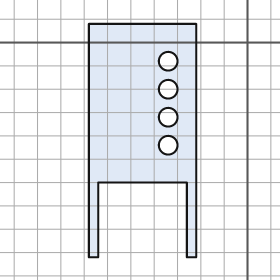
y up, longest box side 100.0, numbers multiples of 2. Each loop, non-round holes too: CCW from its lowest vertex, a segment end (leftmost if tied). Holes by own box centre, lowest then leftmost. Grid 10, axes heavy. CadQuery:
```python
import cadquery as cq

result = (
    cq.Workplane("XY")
    .moveTo(-68.0, -92.0)
    .lineTo(-64.0, -92.0)
    .lineTo(-64.0, -60.0)
    .lineTo(-26.0, -60.0)
    .lineTo(-26.0, -92.0)
    .lineTo(-22.0, -92.0)
    .lineTo(-22.0, 8.0)
    .lineTo(-68.0, 8.0)
    .close()
    .moveTo(-34.0, -44.0)
    .circle(4.0)
    .moveTo(-34.0, -32.0)
    .circle(4.0)
    .moveTo(-34.0, -20.0)
    .circle(4.0)
    .moveTo(-34.0, -8.0)
    .circle(4.0)
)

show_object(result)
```